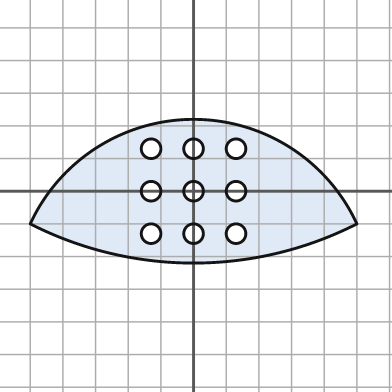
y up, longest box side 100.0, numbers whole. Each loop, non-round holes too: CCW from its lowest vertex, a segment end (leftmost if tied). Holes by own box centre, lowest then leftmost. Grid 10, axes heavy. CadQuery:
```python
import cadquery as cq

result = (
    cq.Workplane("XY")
    .moveTo(-50.0, -10.0)
    .threePointArc((0.0, -22.0), (50.0, -10.0))
    .threePointArc((0.0, 22.0), (-50.0, -10.0))
    .close()
    .moveTo(-13.0, -13.0)
    .circle(3.0)
    .moveTo(0.0, -13.0)
    .circle(3.0)
    .moveTo(13.0, -13.0)
    .circle(3.0)
    .moveTo(-13.0, 0.0)
    .circle(3.0)
    .moveTo(0.0, 0.0)
    .circle(3.0)
    .moveTo(13.0, 0.0)
    .circle(3.0)
    .moveTo(-13.0, 13.0)
    .circle(3.0)
    .moveTo(0.0, 13.0)
    .circle(3.0)
    .moveTo(13.0, 13.0)
    .circle(3.0)
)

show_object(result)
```